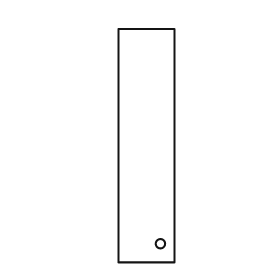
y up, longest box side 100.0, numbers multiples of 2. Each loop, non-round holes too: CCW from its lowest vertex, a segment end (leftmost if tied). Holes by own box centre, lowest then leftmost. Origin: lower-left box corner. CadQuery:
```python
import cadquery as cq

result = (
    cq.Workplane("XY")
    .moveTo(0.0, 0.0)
    .lineTo(24.0, 0.0)
    .lineTo(24.0, 100.0)
    .lineTo(0.0, 100.0)
    .close()
    .moveTo(18.0, 8.0)
    .circle(2.0)
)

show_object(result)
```